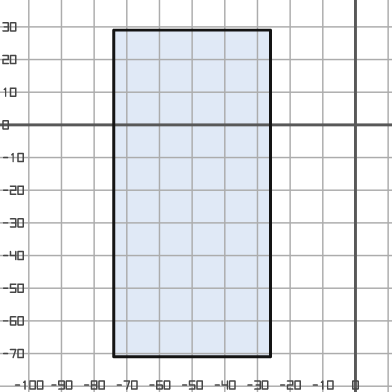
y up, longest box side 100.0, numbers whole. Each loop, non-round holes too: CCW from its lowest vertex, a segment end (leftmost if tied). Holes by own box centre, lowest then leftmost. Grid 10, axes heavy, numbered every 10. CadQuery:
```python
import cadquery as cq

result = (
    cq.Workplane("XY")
    .moveTo(-74.0, -71.0)
    .lineTo(-26.0, -71.0)
    .lineTo(-26.0, 29.0)
    .lineTo(-74.0, 29.0)
    .close()
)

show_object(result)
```